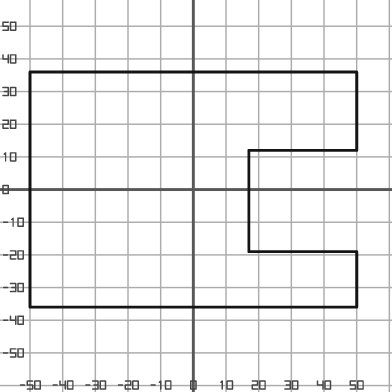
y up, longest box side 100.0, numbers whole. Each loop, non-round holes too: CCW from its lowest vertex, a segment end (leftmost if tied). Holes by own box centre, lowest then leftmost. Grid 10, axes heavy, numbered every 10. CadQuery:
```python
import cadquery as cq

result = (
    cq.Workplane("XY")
    .moveTo(-50.0, -36.0)
    .lineTo(50.0, -36.0)
    .lineTo(50.0, -19.0)
    .lineTo(17.0, -19.0)
    .lineTo(17.0, 12.0)
    .lineTo(50.0, 12.0)
    .lineTo(50.0, 36.0)
    .lineTo(-50.0, 36.0)
    .close()
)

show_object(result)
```